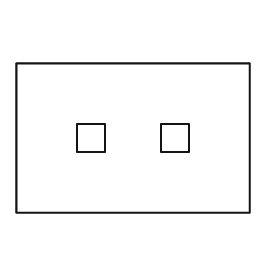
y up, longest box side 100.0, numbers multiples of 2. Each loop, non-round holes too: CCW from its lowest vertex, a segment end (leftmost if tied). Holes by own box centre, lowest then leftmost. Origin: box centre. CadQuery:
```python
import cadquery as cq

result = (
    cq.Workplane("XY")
    .moveTo(-50.0, -32.0)
    .lineTo(50.0, -32.0)
    .lineTo(50.0, 32.0)
    .lineTo(-50.0, 32.0)
    .close()
    .moveTo(-24.0, -6.0)
    .lineTo(-12.0, -6.0)
    .lineTo(-12.0, 6.0)
    .lineTo(-24.0, 6.0)
    .close()
    .moveTo(12.0, -6.0)
    .lineTo(24.0, -6.0)
    .lineTo(24.0, 6.0)
    .lineTo(12.0, 6.0)
    .close()
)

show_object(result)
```